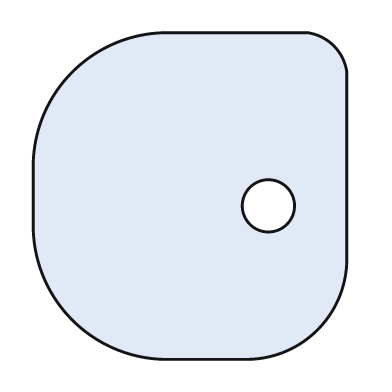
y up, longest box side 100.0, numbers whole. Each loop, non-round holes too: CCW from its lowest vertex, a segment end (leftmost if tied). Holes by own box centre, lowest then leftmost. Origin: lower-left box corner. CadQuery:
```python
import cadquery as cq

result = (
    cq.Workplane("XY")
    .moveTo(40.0, 0.0)
    .lineTo(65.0, 0.0)
    .threePointArc((87.0, 9.0), (96.0, 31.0))
    .lineTo(96.0, 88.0)
    .threePointArc((92.0, 96.0), (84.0, 100.0))
    .lineTo(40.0, 100.0)
    .threePointArc((12.0, 88.0), (0.0, 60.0))
    .lineTo(0.0, 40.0)
    .threePointArc((12.0, 12.0), (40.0, 0.0))
    .close()
    .moveTo(72.0, 47.0)
    .circle(8.0)
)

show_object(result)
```